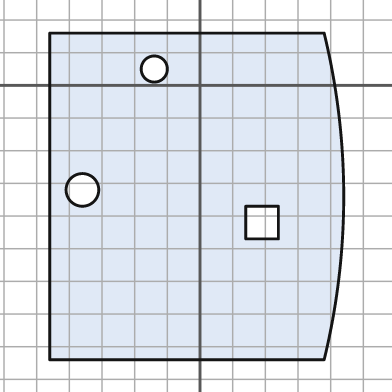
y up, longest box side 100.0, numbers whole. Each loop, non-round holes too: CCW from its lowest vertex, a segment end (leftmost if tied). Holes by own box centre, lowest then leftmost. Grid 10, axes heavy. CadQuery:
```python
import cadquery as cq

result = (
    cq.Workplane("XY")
    .moveTo(-46.0, -84.0)
    .lineTo(38.0, -84.0)
    .threePointArc((44.0, -34.0), (38.0, 16.0))
    .lineTo(-46.0, 16.0)
    .close()
    .moveTo(14.0, -47.0)
    .lineTo(24.0, -47.0)
    .lineTo(24.0, -37.0)
    .lineTo(14.0, -37.0)
    .close()
    .moveTo(-36.0, -32.0)
    .circle(5.0)
    .moveTo(-14.0, 5.0)
    .circle(4.0)
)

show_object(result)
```